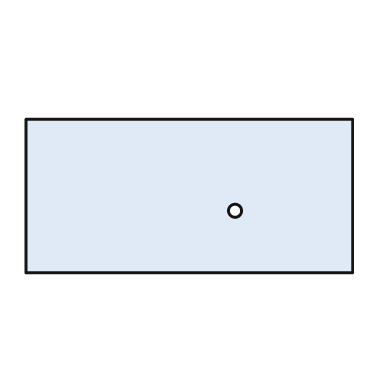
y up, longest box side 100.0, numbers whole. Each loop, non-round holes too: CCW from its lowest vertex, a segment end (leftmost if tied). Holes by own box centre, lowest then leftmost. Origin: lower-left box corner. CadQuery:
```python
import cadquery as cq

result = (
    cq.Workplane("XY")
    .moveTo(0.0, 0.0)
    .lineTo(100.0, 0.0)
    .lineTo(100.0, 47.0)
    .lineTo(0.0, 47.0)
    .close()
    .moveTo(64.0, 19.0)
    .circle(2.0)
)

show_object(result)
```